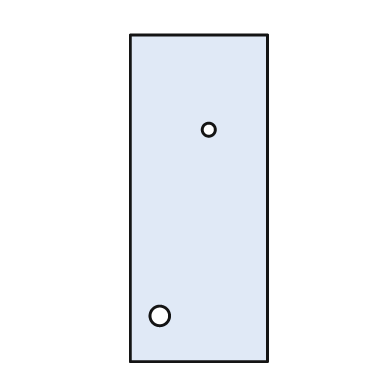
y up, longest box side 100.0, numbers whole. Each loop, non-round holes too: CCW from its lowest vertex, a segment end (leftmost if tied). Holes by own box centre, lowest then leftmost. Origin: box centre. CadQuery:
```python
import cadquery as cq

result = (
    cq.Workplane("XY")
    .moveTo(-21.0, -50.0)
    .lineTo(21.0, -50.0)
    .lineTo(21.0, 50.0)
    .lineTo(-21.0, 50.0)
    .close()
    .moveTo(-12.0, -36.0)
    .circle(3.0)
    .moveTo(3.0, 21.0)
    .circle(2.0)
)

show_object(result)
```